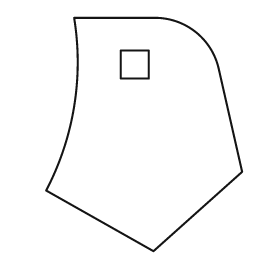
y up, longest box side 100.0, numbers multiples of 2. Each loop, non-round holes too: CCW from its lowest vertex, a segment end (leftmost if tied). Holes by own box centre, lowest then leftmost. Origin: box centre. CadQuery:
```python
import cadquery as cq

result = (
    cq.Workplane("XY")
    .moveTo(4.0, -50.0)
    .lineTo(42.0, -16.0)
    .lineTo(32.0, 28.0)
    .threePointArc((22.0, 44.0), (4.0, 50.0))
    .lineTo(-30.0, 50.0)
    .threePointArc((-30.0, 12.0), (-42.0, -24.0))
    .close()
    .moveTo(-10.0, 24.0)
    .lineTo(2.0, 24.0)
    .lineTo(2.0, 36.0)
    .lineTo(-10.0, 36.0)
    .close()
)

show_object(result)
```